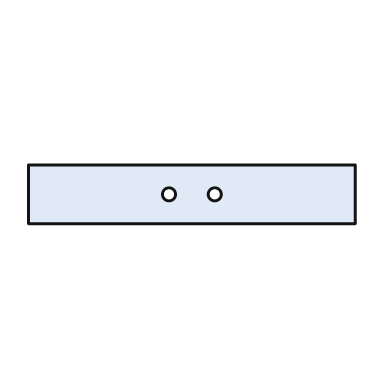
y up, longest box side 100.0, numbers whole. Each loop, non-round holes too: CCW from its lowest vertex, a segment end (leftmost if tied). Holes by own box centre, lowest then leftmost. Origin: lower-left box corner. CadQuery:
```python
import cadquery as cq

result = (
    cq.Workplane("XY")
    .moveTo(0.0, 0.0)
    .lineTo(100.0, 0.0)
    .lineTo(100.0, 18.0)
    .lineTo(0.0, 18.0)
    .close()
    .moveTo(43.0, 9.0)
    .circle(2.0)
    .moveTo(57.0, 9.0)
    .circle(2.0)
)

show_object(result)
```